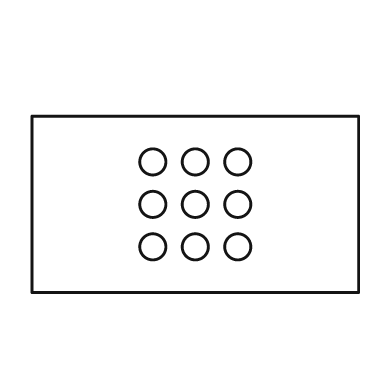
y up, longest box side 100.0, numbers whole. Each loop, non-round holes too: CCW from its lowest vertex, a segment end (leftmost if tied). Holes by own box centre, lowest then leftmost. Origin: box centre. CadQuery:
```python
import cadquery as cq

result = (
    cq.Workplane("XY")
    .moveTo(-50.0, -27.0)
    .lineTo(50.0, -27.0)
    .lineTo(50.0, 27.0)
    .lineTo(-50.0, 27.0)
    .close()
    .moveTo(-13.0, -13.0)
    .circle(4.0)
    .moveTo(0.0, -13.0)
    .circle(4.0)
    .moveTo(13.0, -13.0)
    .circle(4.0)
    .moveTo(-13.0, 0.0)
    .circle(4.0)
    .moveTo(0.0, 0.0)
    .circle(4.0)
    .moveTo(13.0, 0.0)
    .circle(4.0)
    .moveTo(-13.0, 13.0)
    .circle(4.0)
    .moveTo(0.0, 13.0)
    .circle(4.0)
    .moveTo(13.0, 13.0)
    .circle(4.0)
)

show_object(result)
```